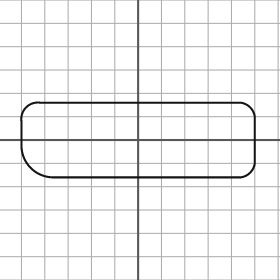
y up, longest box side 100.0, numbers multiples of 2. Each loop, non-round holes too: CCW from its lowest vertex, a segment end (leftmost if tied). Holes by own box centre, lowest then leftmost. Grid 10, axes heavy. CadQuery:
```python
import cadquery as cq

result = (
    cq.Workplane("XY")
    .moveTo(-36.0, -16.0)
    .lineTo(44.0, -16.0)
    .threePointArc((48.0, -14.0), (50.0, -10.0))
    .lineTo(50.0, 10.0)
    .threePointArc((48.0, 14.0), (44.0, 16.0))
    .lineTo(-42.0, 16.0)
    .threePointArc((-48.0, 14.0), (-50.0, 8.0))
    .lineTo(-50.0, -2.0)
    .threePointArc((-46.0, -12.0), (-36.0, -16.0))
    .close()
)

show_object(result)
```